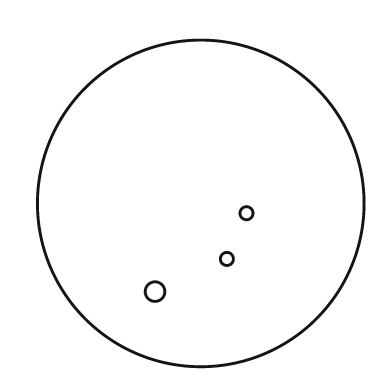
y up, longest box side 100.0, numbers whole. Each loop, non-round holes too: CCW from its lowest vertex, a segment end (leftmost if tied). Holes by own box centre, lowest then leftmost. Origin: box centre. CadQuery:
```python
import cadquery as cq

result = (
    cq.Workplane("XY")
    .moveTo(0.0, 0.0)
    .circle(50.0)
    .moveTo(-14.0, -27.0)
    .circle(3.0)
    .moveTo(8.0, -17.0)
    .circle(2.0)
    .moveTo(14.0, -3.0)
    .circle(2.0)
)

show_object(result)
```